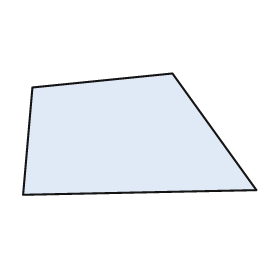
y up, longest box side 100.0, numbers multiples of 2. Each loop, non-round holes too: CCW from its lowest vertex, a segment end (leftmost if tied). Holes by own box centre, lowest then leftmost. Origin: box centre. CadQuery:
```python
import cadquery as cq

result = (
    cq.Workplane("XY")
    .moveTo(-50.0, -26.0)
    .lineTo(50.0, -24.0)
    .lineTo(14.0, 26.0)
    .lineTo(-46.0, 20.0)
    .close()
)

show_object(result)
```